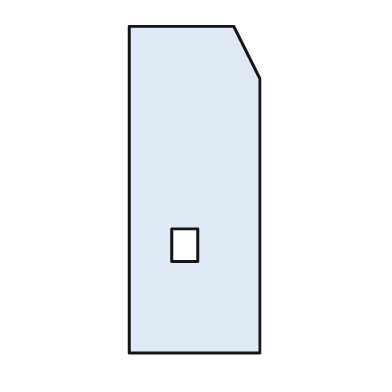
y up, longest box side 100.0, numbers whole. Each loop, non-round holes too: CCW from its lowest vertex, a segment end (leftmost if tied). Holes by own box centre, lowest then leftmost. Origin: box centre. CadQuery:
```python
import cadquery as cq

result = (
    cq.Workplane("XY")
    .moveTo(-20.0, -50.0)
    .lineTo(20.0, -50.0)
    .lineTo(20.0, 34.0)
    .lineTo(12.0, 50.0)
    .lineTo(-20.0, 50.0)
    .close()
    .moveTo(-7.0, -22.0)
    .lineTo(1.0, -22.0)
    .lineTo(1.0, -12.0)
    .lineTo(-7.0, -12.0)
    .close()
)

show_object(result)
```